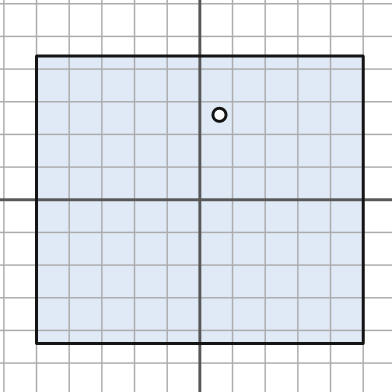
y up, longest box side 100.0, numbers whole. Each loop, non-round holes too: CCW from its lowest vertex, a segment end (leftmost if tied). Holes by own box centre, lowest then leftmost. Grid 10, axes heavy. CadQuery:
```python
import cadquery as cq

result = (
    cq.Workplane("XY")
    .moveTo(-50.0, -44.0)
    .lineTo(50.0, -44.0)
    .lineTo(50.0, 44.0)
    .lineTo(-50.0, 44.0)
    .close()
    .moveTo(6.0, 26.0)
    .circle(2.0)
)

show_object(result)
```